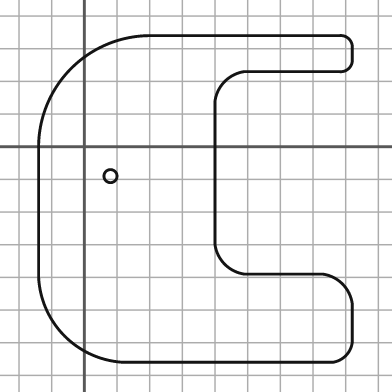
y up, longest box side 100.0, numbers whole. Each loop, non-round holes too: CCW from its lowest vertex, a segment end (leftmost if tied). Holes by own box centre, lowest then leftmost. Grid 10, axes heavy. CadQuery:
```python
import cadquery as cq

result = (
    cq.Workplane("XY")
    .moveTo(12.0, -66.0)
    .lineTo(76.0, -66.0)
    .threePointArc((80.0, -64.0), (82.0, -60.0))
    .lineTo(82.0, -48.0)
    .threePointArc((79.0, -42.0), (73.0, -39.0))
    .lineTo(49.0, -39.0)
    .threePointArc((43.0, -36.0), (40.0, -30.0))
    .lineTo(40.0, 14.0)
    .threePointArc((43.0, 20.0), (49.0, 23.0))
    .lineTo(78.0, 23.0)
    .threePointArc((81.0, 24.0), (82.0, 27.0))
    .lineTo(82.0, 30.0)
    .threePointArc((81.0, 33.0), (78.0, 34.0))
    .lineTo(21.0, 34.0)
    .threePointArc((-4.0, 24.0), (-14.0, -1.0))
    .lineTo(-14.0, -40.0)
    .threePointArc((-6.0, -58.0), (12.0, -66.0))
    .close()
    .moveTo(8.0, -9.0)
    .circle(2.0)
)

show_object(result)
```